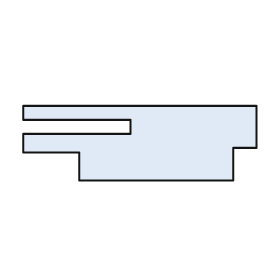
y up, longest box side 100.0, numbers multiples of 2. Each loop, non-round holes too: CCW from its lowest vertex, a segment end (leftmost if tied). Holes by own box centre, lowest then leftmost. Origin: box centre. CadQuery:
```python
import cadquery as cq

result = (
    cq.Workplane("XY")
    .moveTo(-26.0, -16.0)
    .lineTo(40.0, -16.0)
    .lineTo(40.0, -2.0)
    .lineTo(50.0, -2.0)
    .lineTo(50.0, 16.0)
    .lineTo(-50.0, 16.0)
    .lineTo(-50.0, 10.0)
    .lineTo(-4.0, 10.0)
    .lineTo(-4.0, 4.0)
    .lineTo(-50.0, 4.0)
    .lineTo(-50.0, -4.0)
    .lineTo(-26.0, -4.0)
    .close()
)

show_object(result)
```